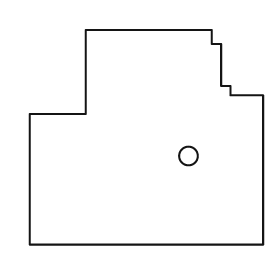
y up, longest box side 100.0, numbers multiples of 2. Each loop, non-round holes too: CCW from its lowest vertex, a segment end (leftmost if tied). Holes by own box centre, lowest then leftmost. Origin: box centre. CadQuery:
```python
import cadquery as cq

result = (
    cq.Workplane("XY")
    .moveTo(-50.0, -46.0)
    .lineTo(50.0, -46.0)
    .lineTo(50.0, 18.0)
    .lineTo(36.0, 18.0)
    .lineTo(36.0, 22.0)
    .lineTo(32.0, 22.0)
    .lineTo(32.0, 40.0)
    .lineTo(28.0, 40.0)
    .lineTo(28.0, 46.0)
    .lineTo(-26.0, 46.0)
    .lineTo(-26.0, 10.0)
    .lineTo(-50.0, 10.0)
    .close()
    .moveTo(18.0, -8.0)
    .circle(4.0)
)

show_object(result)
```